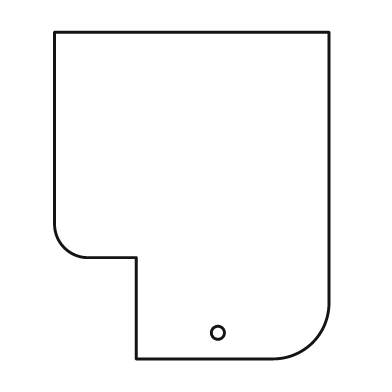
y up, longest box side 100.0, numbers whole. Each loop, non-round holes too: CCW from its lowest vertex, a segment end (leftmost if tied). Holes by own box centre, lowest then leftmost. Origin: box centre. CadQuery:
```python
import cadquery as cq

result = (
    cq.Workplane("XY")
    .moveTo(-17.0, -50.0)
    .lineTo(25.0, -50.0)
    .threePointArc((37.0, -45.0), (42.0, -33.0))
    .lineTo(42.0, 50.0)
    .lineTo(-42.0, 50.0)
    .lineTo(-42.0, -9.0)
    .threePointArc((-39.0, -16.0), (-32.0, -19.0))
    .lineTo(-17.0, -19.0)
    .close()
    .moveTo(8.0, -42.0)
    .circle(2.0)
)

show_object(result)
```